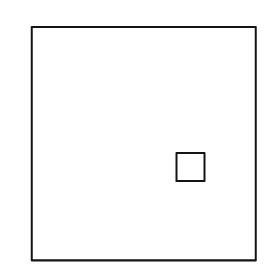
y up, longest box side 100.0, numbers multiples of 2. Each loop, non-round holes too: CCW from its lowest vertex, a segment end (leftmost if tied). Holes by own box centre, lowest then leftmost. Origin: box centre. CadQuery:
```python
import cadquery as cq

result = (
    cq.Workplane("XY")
    .moveTo(-48.0, -50.0)
    .lineTo(48.0, -50.0)
    .lineTo(48.0, 50.0)
    .lineTo(-48.0, 50.0)
    .close()
    .moveTo(14.0, -16.0)
    .lineTo(26.0, -16.0)
    .lineTo(26.0, -4.0)
    .lineTo(14.0, -4.0)
    .close()
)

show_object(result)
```